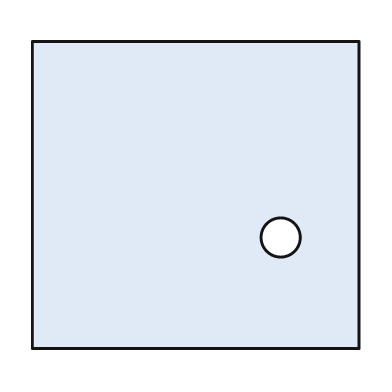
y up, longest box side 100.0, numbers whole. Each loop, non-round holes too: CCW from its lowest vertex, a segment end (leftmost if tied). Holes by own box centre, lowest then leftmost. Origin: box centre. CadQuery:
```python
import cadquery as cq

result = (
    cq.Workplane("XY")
    .moveTo(-50.0, -47.0)
    .lineTo(50.0, -47.0)
    .lineTo(50.0, 47.0)
    .lineTo(-50.0, 47.0)
    .close()
    .moveTo(26.0, -13.0)
    .circle(6.0)
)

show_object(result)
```